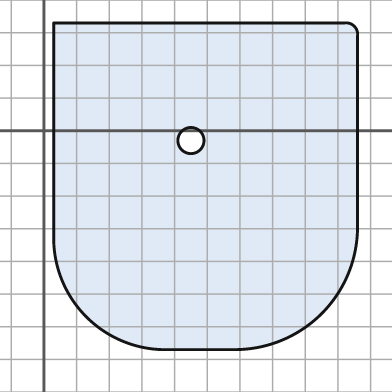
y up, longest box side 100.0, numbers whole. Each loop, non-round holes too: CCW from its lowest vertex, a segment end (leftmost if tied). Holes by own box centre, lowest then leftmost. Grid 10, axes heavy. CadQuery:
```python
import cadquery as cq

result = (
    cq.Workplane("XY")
    .moveTo(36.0, -67.0)
    .lineTo(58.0, -67.0)
    .threePointArc((85.0, -56.0), (96.0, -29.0))
    .lineTo(96.0, 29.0)
    .threePointArc((95.0, 32.0), (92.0, 33.0))
    .lineTo(3.0, 33.0)
    .lineTo(3.0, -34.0)
    .threePointArc((13.0, -57.0), (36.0, -67.0))
    .close()
    .moveTo(45.0, -3.0)
    .circle(4.0)
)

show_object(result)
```